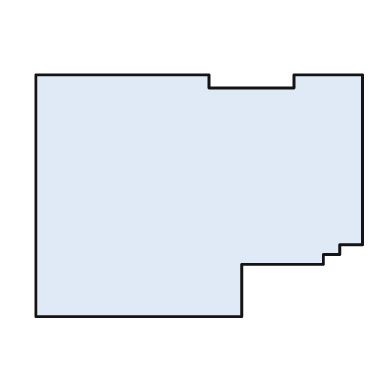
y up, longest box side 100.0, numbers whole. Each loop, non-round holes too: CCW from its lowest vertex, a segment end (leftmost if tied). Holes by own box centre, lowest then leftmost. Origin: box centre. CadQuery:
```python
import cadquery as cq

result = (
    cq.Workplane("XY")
    .moveTo(-50.0, -37.0)
    .lineTo(13.0, -37.0)
    .lineTo(13.0, -21.0)
    .lineTo(38.0, -21.0)
    .lineTo(38.0, -18.0)
    .lineTo(43.0, -18.0)
    .lineTo(43.0, -15.0)
    .lineTo(50.0, -15.0)
    .lineTo(50.0, 37.0)
    .lineTo(29.0, 37.0)
    .lineTo(29.0, 33.0)
    .lineTo(3.0, 33.0)
    .lineTo(3.0, 37.0)
    .lineTo(-50.0, 37.0)
    .close()
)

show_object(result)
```